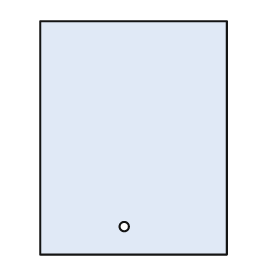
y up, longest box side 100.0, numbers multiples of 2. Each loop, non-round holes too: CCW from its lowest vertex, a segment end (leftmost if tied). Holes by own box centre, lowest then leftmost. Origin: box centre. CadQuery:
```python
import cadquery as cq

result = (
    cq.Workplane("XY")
    .moveTo(-40.0, -50.0)
    .lineTo(40.0, -50.0)
    .lineTo(40.0, 50.0)
    .lineTo(-40.0, 50.0)
    .close()
    .moveTo(-4.0, -38.0)
    .circle(2.0)
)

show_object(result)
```